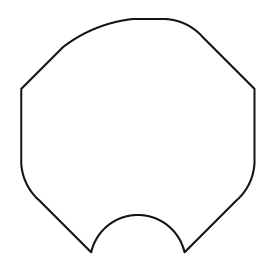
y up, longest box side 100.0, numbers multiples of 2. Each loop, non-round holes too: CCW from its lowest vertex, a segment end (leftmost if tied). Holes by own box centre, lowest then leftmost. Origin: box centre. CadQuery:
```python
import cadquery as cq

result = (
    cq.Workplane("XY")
    .moveTo(-20.0, -50.0)
    .threePointArc((0.0, -34.0), (20.0, -50.0))
    .lineTo(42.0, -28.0)
    .threePointArc((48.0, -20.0), (50.0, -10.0))
    .lineTo(50.0, 20.0)
    .lineTo(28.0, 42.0)
    .threePointArc((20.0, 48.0), (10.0, 50.0))
    .lineTo(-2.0, 50.0)
    .threePointArc((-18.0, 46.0), (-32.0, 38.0))
    .lineTo(-50.0, 20.0)
    .lineTo(-50.0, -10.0)
    .threePointArc((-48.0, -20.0), (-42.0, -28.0))
    .close()
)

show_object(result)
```